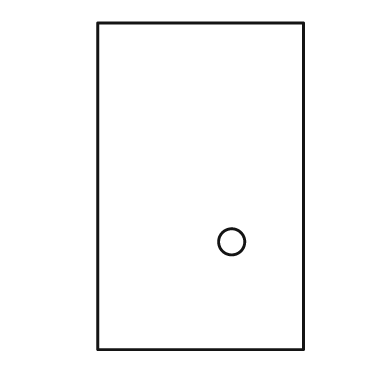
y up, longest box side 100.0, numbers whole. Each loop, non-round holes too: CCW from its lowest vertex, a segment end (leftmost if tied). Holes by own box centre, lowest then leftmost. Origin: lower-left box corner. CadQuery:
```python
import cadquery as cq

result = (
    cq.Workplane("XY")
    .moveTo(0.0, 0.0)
    .lineTo(63.0, 0.0)
    .lineTo(63.0, 100.0)
    .lineTo(0.0, 100.0)
    .close()
    .moveTo(41.0, 33.0)
    .circle(4.0)
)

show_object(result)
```